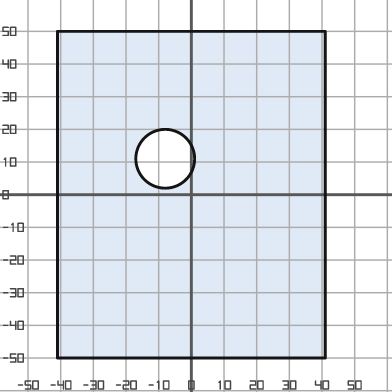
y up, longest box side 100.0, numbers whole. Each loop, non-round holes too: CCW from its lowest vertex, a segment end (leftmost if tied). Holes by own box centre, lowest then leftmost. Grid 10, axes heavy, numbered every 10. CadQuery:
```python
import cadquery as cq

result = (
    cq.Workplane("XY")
    .moveTo(-41.0, -50.0)
    .lineTo(41.0, -50.0)
    .lineTo(41.0, 50.0)
    .lineTo(-41.0, 50.0)
    .close()
    .moveTo(-8.0, 11.0)
    .circle(9.0)
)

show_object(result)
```